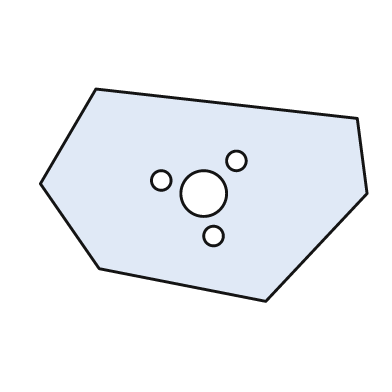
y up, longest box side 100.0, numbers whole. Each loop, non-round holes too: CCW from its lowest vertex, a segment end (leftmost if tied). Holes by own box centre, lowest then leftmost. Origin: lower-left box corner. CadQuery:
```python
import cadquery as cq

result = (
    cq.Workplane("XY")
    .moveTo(69.0, 0.0)
    .lineTo(100.0, 33.0)
    .lineTo(97.0, 56.0)
    .lineTo(17.0, 65.0)
    .lineTo(0.0, 36.0)
    .lineTo(18.0, 10.0)
    .close()
    .moveTo(53.0, 20.0)
    .circle(3.0)
    .moveTo(50.0, 33.0)
    .circle(7.0)
    .moveTo(37.0, 37.0)
    .circle(3.0)
    .moveTo(60.0, 43.0)
    .circle(3.0)
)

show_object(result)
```